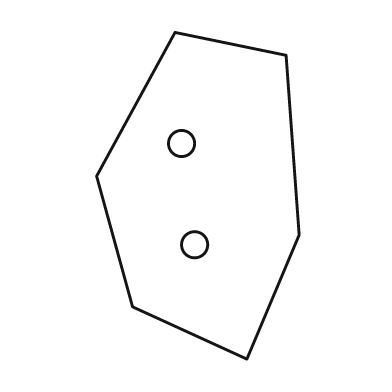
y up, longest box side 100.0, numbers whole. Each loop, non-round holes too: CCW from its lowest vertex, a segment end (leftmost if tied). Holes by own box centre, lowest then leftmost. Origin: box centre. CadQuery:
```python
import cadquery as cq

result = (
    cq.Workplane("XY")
    .moveTo(15.0, -50.0)
    .lineTo(31.0, -12.0)
    .lineTo(27.0, 43.0)
    .lineTo(-7.0, 50.0)
    .lineTo(-31.0, 6.0)
    .lineTo(-20.0, -34.0)
    .close()
    .moveTo(-1.0, -15.0)
    .circle(4.0)
    .moveTo(-5.0, 16.0)
    .circle(4.0)
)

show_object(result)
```